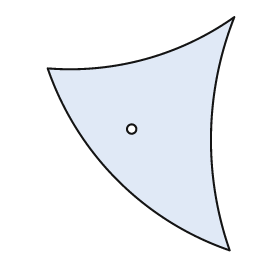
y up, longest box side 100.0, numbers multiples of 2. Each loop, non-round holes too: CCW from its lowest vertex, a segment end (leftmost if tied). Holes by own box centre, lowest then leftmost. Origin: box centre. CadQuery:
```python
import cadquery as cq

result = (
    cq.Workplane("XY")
    .moveTo(38.0, -50.0)
    .threePointArc((30.0, 0.0), (40.0, 50.0))
    .threePointArc((2.0, 32.0), (-40.0, 28.0))
    .threePointArc((-10.0, -20.0), (38.0, -50.0))
    .close()
    .moveTo(-4.0, 2.0)
    .circle(2.0)
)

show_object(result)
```